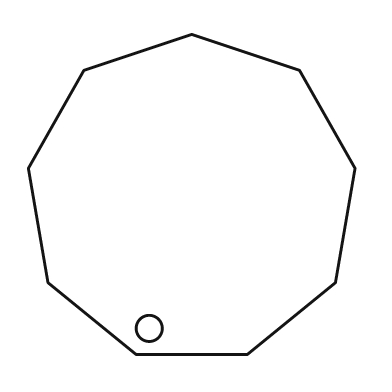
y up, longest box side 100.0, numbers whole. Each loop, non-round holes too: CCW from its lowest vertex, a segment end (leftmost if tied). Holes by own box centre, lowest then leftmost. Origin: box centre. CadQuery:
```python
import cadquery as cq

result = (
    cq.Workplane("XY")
    .moveTo(-17.0, -49.0)
    .lineTo(17.0, -49.0)
    .lineTo(44.0, -27.0)
    .lineTo(50.0, 8.0)
    .lineTo(33.0, 38.0)
    .lineTo(0.0, 49.0)
    .lineTo(-33.0, 38.0)
    .lineTo(-50.0, 8.0)
    .lineTo(-44.0, -27.0)
    .close()
    .moveTo(-13.0, -41.0)
    .circle(4.0)
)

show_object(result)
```